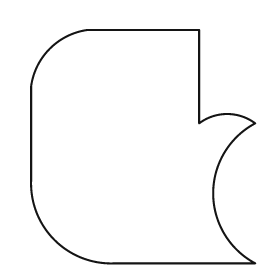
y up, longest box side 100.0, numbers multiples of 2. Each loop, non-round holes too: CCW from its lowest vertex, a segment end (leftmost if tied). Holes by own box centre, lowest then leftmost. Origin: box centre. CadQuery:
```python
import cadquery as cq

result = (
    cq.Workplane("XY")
    .moveTo(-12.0, -50.0)
    .lineTo(48.0, -50.0)
    .threePointArc((30.0, -20.0), (48.0, 10.0))
    .threePointArc((36.0, 14.0), (24.0, 10.0))
    .lineTo(24.0, 50.0)
    .lineTo(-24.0, 50.0)
    .threePointArc((-40.0, 42.0), (-48.0, 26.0))
    .lineTo(-48.0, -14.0)
    .threePointArc((-38.0, -40.0), (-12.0, -50.0))
    .close()
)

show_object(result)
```